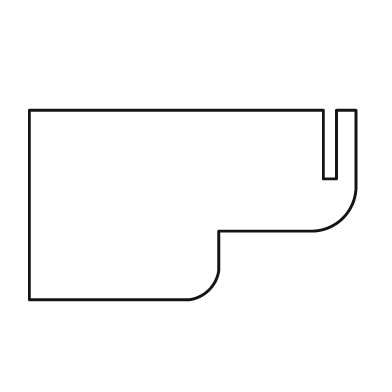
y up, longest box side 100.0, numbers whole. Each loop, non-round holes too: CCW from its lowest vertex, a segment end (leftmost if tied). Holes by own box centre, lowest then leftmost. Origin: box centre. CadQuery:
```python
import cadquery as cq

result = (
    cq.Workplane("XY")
    .moveTo(-50.0, -29.0)
    .lineTo(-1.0, -29.0)
    .threePointArc((5.0, -26.0), (8.0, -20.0))
    .lineTo(8.0, -8.0)
    .lineTo(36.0, -8.0)
    .threePointArc((46.0, -4.0), (50.0, 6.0))
    .lineTo(50.0, 29.0)
    .lineTo(44.0, 29.0)
    .lineTo(44.0, 8.0)
    .lineTo(40.0, 8.0)
    .lineTo(40.0, 29.0)
    .lineTo(-50.0, 29.0)
    .close()
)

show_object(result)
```